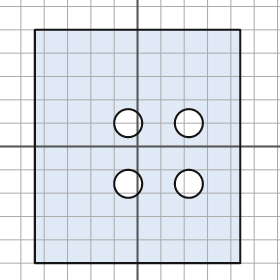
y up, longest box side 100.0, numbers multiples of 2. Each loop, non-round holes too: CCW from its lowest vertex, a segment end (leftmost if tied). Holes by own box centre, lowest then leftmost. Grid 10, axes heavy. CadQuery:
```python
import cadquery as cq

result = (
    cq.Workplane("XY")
    .moveTo(-44.0, -50.0)
    .lineTo(44.0, -50.0)
    .lineTo(44.0, 50.0)
    .lineTo(-44.0, 50.0)
    .close()
    .moveTo(-4.0, -16.0)
    .circle(6.0)
    .moveTo(22.0, -16.0)
    .circle(6.0)
    .moveTo(-4.0, 10.0)
    .circle(6.0)
    .moveTo(22.0, 10.0)
    .circle(6.0)
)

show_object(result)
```